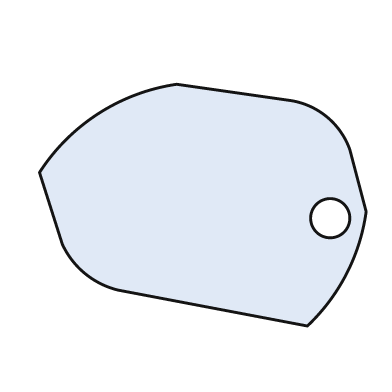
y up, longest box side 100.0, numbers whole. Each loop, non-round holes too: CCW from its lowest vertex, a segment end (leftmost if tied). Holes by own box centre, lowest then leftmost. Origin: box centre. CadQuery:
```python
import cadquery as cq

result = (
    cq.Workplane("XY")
    .moveTo(32.0, -37.0)
    .threePointArc((44.0, -21.0), (50.0, -2.0))
    .lineTo(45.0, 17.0)
    .threePointArc((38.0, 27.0), (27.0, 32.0))
    .lineTo(-8.0, 37.0)
    .threePointArc((-32.0, 28.0), (-50.0, 10.0))
    .lineTo(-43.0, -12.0)
    .threePointArc((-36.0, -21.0), (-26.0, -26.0))
    .close()
    .moveTo(39.0, -4.0)
    .circle(6.0)
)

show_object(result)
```